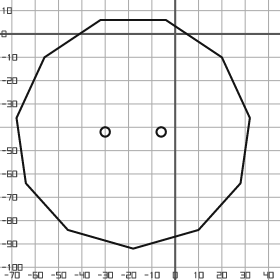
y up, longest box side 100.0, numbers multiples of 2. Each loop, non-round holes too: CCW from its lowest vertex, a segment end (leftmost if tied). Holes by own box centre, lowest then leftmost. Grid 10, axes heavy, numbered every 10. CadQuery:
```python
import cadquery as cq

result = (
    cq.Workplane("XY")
    .moveTo(-18.0, -92.0)
    .lineTo(10.0, -84.0)
    .lineTo(28.0, -64.0)
    .lineTo(32.0, -36.0)
    .lineTo(20.0, -10.0)
    .lineTo(-4.0, 6.0)
    .lineTo(-32.0, 6.0)
    .lineTo(-56.0, -10.0)
    .lineTo(-68.0, -36.0)
    .lineTo(-64.0, -64.0)
    .lineTo(-46.0, -84.0)
    .close()
    .moveTo(-30.0, -42.0)
    .circle(2.0)
    .moveTo(-6.0, -42.0)
    .circle(2.0)
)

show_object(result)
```